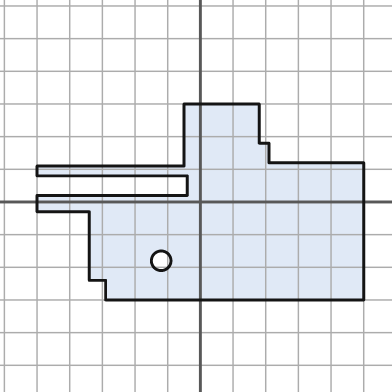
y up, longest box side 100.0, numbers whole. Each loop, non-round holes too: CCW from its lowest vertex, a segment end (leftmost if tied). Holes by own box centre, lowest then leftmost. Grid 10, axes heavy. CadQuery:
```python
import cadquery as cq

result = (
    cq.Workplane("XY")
    .moveTo(-29.0, -30.0)
    .lineTo(50.0, -30.0)
    .lineTo(50.0, 12.0)
    .lineTo(21.0, 12.0)
    .lineTo(21.0, 18.0)
    .lineTo(18.0, 18.0)
    .lineTo(18.0, 30.0)
    .lineTo(-5.0, 30.0)
    .lineTo(-5.0, 11.0)
    .lineTo(-50.0, 11.0)
    .lineTo(-50.0, 8.0)
    .lineTo(-4.0, 8.0)
    .lineTo(-4.0, 2.0)
    .lineTo(-50.0, 2.0)
    .lineTo(-50.0, -3.0)
    .lineTo(-34.0, -3.0)
    .lineTo(-34.0, -24.0)
    .lineTo(-29.0, -24.0)
    .close()
    .moveTo(-12.0, -18.0)
    .circle(3.0)
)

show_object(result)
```